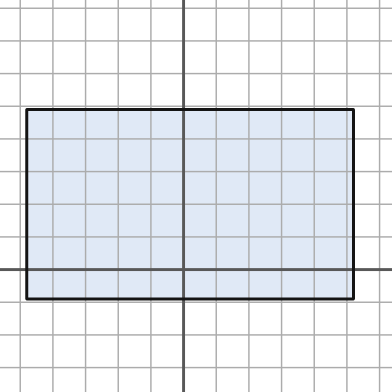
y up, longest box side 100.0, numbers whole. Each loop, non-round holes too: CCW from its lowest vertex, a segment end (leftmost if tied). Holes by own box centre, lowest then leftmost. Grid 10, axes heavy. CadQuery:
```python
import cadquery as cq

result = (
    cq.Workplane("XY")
    .moveTo(-48.0, -9.0)
    .lineTo(52.0, -9.0)
    .lineTo(52.0, 49.0)
    .lineTo(-48.0, 49.0)
    .close()
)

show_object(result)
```